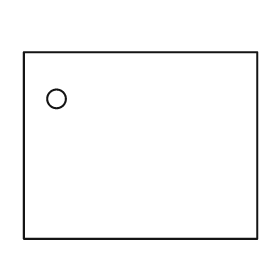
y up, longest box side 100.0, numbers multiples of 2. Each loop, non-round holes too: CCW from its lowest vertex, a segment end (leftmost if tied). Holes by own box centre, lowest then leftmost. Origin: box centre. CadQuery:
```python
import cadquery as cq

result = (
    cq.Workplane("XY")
    .moveTo(-50.0, -40.0)
    .lineTo(50.0, -40.0)
    .lineTo(50.0, 40.0)
    .lineTo(-50.0, 40.0)
    .close()
    .moveTo(-36.0, 20.0)
    .circle(4.0)
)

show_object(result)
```